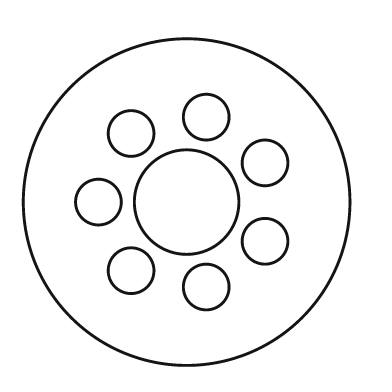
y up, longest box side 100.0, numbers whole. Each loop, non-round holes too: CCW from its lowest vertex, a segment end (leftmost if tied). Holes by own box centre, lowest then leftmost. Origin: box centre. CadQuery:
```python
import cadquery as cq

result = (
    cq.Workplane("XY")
    .moveTo(0.0, 0.0)
    .circle(50.0)
    .moveTo(6.0, -26.0)
    .circle(7.0)
    .moveTo(-17.0, -21.0)
    .circle(7.0)
    .moveTo(24.0, -12.0)
    .circle(7.0)
    .moveTo(-27.0, 0.0)
    .circle(7.0)
    .moveTo(0.0, 0.0)
    .circle(16.0)
    .moveTo(24.0, 12.0)
    .circle(7.0)
    .moveTo(-17.0, 21.0)
    .circle(7.0)
    .moveTo(6.0, 26.0)
    .circle(7.0)
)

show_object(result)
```